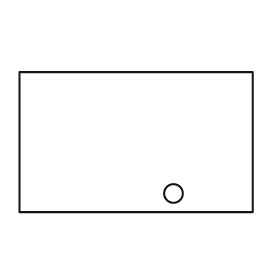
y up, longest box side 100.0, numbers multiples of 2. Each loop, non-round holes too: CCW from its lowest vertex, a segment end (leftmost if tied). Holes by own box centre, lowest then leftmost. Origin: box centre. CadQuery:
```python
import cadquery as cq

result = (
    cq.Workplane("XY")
    .moveTo(-50.0, -30.0)
    .lineTo(50.0, -30.0)
    .lineTo(50.0, 30.0)
    .lineTo(-50.0, 30.0)
    .close()
    .moveTo(16.0, -22.0)
    .circle(4.0)
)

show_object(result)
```